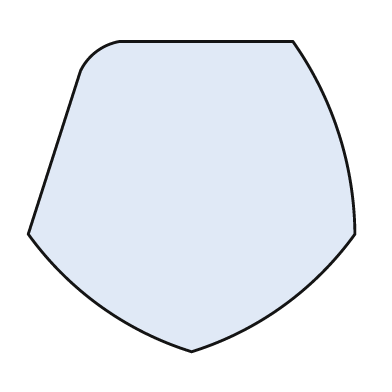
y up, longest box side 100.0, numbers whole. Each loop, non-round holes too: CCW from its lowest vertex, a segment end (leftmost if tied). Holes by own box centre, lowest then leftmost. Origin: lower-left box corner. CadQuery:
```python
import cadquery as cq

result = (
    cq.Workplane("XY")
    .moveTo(50.0, 0.0)
    .threePointArc((78.0, 14.0), (100.0, 36.0))
    .threePointArc((95.0, 67.0), (81.0, 95.0))
    .lineTo(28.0, 95.0)
    .threePointArc((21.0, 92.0), (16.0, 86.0))
    .lineTo(0.0, 36.0)
    .threePointArc((22.0, 14.0), (50.0, 0.0))
    .close()
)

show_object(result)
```